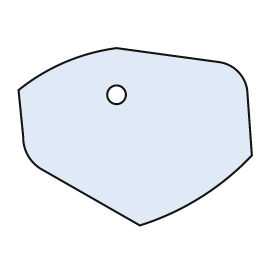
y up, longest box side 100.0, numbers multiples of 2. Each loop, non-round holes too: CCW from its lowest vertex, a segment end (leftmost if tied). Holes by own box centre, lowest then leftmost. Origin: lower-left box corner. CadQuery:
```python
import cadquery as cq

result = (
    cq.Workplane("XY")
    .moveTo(52.0, 0.0)
    .threePointArc((78.0, 12.0), (100.0, 30.0))
    .lineTo(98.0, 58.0)
    .threePointArc((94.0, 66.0), (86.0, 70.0))
    .lineTo(42.0, 76.0)
    .threePointArc((20.0, 70.0), (0.0, 58.0))
    .lineTo(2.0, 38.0)
    .threePointArc((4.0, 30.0), (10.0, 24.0))
    .close()
    .moveTo(42.0, 56.0)
    .circle(4.0)
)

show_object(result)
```